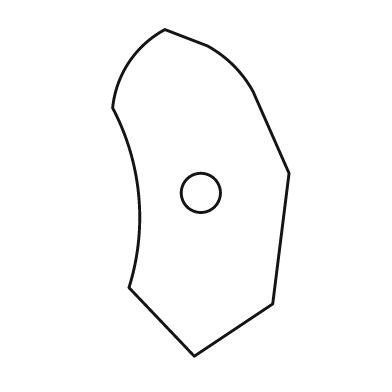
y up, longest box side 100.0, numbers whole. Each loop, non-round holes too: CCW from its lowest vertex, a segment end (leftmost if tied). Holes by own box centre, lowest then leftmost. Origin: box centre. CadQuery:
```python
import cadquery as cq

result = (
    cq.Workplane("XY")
    .moveTo(-2.0, -50.0)
    .lineTo(22.0, -34.0)
    .lineTo(27.0, 6.0)
    .lineTo(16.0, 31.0)
    .threePointArc((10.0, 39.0), (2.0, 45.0))
    .lineTo(-11.0, 50.0)
    .threePointArc((-22.0, 40.0), (-27.0, 26.0))
    .threePointArc((-19.0, -1.0), (-22.0, -29.0))
    .close()
    .moveTo(0.0, 0.0)
    .circle(6.0)
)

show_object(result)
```